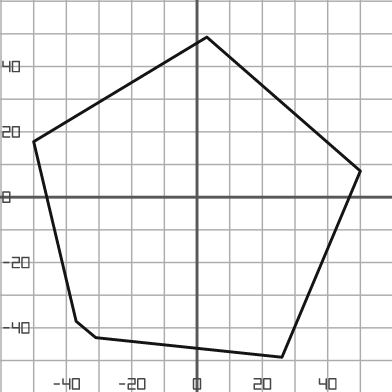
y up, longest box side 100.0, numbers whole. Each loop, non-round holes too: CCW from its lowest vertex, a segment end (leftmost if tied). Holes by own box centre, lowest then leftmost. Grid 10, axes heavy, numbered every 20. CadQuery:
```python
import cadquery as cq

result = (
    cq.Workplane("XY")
    .moveTo(26.0, -49.0)
    .lineTo(50.0, 8.0)
    .lineTo(3.0, 49.0)
    .lineTo(-50.0, 17.0)
    .lineTo(-37.0, -38.0)
    .lineTo(-31.0, -43.0)
    .close()
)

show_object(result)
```